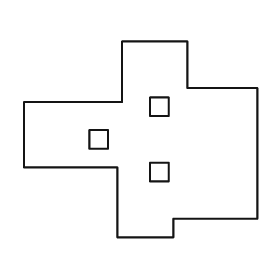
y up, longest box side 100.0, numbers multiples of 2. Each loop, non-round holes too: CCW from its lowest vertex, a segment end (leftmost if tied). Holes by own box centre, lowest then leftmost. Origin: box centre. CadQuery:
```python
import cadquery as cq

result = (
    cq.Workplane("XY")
    .moveTo(-10.0, -42.0)
    .lineTo(14.0, -42.0)
    .lineTo(14.0, -34.0)
    .lineTo(50.0, -34.0)
    .lineTo(50.0, 22.0)
    .lineTo(20.0, 22.0)
    .lineTo(20.0, 42.0)
    .lineTo(-8.0, 42.0)
    .lineTo(-8.0, 16.0)
    .lineTo(-50.0, 16.0)
    .lineTo(-50.0, -12.0)
    .lineTo(-10.0, -12.0)
    .close()
    .moveTo(4.0, -18.0)
    .lineTo(12.0, -18.0)
    .lineTo(12.0, -10.0)
    .lineTo(4.0, -10.0)
    .close()
    .moveTo(-22.0, -4.0)
    .lineTo(-14.0, -4.0)
    .lineTo(-14.0, 4.0)
    .lineTo(-22.0, 4.0)
    .close()
    .moveTo(4.0, 10.0)
    .lineTo(12.0, 10.0)
    .lineTo(12.0, 18.0)
    .lineTo(4.0, 18.0)
    .close()
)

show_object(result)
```